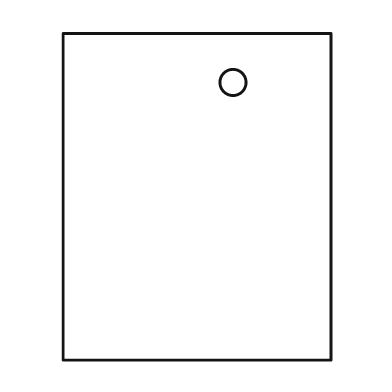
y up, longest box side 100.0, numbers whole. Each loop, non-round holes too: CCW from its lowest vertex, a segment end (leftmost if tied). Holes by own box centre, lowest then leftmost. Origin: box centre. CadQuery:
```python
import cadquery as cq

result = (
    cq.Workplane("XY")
    .moveTo(-41.0, -50.0)
    .lineTo(41.0, -50.0)
    .lineTo(41.0, 50.0)
    .lineTo(-41.0, 50.0)
    .close()
    .moveTo(11.0, 35.0)
    .circle(4.0)
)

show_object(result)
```